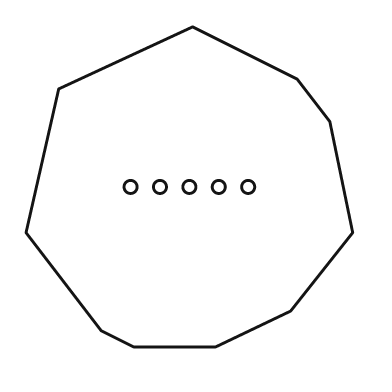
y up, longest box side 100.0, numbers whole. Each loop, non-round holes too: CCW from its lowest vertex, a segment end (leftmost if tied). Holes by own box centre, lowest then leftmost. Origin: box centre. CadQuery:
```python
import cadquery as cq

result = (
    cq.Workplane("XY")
    .moveTo(-17.0, -49.0)
    .lineTo(8.0, -49.0)
    .lineTo(31.0, -38.0)
    .lineTo(50.0, -14.0)
    .lineTo(43.0, 20.0)
    .lineTo(33.0, 33.0)
    .lineTo(1.0, 49.0)
    .lineTo(-40.0, 30.0)
    .lineTo(-50.0, -14.0)
    .lineTo(-27.0, -44.0)
    .close()
    .moveTo(-18.0, 0.0)
    .circle(2.0)
    .moveTo(-9.0, 0.0)
    .circle(2.0)
    .moveTo(0.0, 0.0)
    .circle(2.0)
    .moveTo(9.0, 0.0)
    .circle(2.0)
    .moveTo(18.0, 0.0)
    .circle(2.0)
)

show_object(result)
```